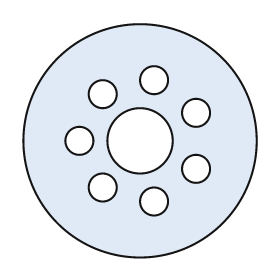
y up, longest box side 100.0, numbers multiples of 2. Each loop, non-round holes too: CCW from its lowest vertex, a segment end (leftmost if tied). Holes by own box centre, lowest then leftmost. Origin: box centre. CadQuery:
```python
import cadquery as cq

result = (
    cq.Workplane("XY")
    .moveTo(0.0, 0.0)
    .circle(50.0)
    .moveTo(6.0, -26.0)
    .circle(6.0)
    .moveTo(-16.0, -20.0)
    .circle(6.0)
    .moveTo(24.0, -12.0)
    .circle(6.0)
    .moveTo(-26.0, 0.0)
    .circle(6.0)
    .moveTo(0.0, 0.0)
    .circle(14.0)
    .moveTo(24.0, 12.0)
    .circle(6.0)
    .moveTo(-16.0, 20.0)
    .circle(6.0)
    .moveTo(6.0, 26.0)
    .circle(6.0)
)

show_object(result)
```